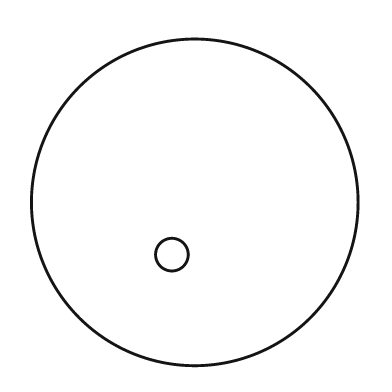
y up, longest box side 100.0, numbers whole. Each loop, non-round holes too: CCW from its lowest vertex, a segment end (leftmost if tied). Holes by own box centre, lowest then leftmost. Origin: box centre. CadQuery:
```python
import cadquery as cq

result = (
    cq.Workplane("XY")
    .moveTo(0.0, 0.0)
    .circle(50.0)
    .moveTo(-7.0, -16.0)
    .circle(5.0)
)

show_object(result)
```